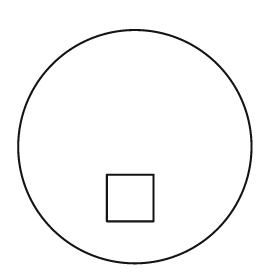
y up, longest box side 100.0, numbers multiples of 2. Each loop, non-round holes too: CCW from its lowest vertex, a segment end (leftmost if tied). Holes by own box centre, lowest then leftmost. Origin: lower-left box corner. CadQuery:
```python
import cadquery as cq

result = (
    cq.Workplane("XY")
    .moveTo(50.0, 50.0)
    .circle(50.0)
    .moveTo(38.0, 18.0)
    .lineTo(58.0, 18.0)
    .lineTo(58.0, 38.0)
    .lineTo(38.0, 38.0)
    .close()
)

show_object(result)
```